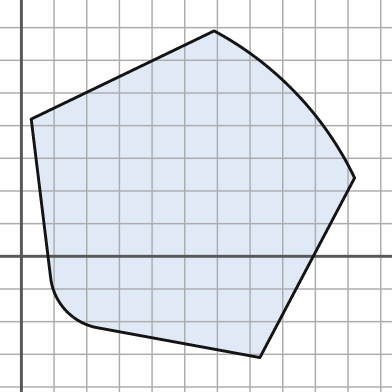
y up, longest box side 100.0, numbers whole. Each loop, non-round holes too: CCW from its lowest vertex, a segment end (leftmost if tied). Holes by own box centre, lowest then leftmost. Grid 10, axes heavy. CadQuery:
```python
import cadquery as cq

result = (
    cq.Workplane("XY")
    .moveTo(73.0, -31.0)
    .lineTo(102.0, 24.0)
    .threePointArc((84.0, 50.0), (59.0, 69.0))
    .lineTo(3.0, 42.0)
    .lineTo(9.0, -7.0)
    .threePointArc((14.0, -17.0), (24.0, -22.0))
    .close()
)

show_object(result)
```